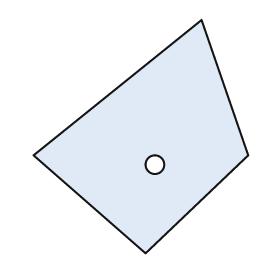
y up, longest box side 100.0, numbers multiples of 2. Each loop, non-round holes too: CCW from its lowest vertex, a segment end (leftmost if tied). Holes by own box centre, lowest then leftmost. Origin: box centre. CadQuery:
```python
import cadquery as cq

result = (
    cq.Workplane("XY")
    .moveTo(2.0, -50.0)
    .lineTo(46.0, -8.0)
    .lineTo(26.0, 50.0)
    .lineTo(-46.0, -8.0)
    .close()
    .moveTo(6.0, -12.0)
    .circle(4.0)
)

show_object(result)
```